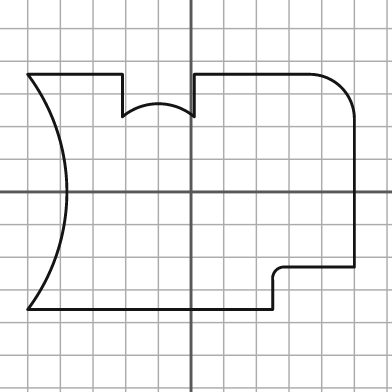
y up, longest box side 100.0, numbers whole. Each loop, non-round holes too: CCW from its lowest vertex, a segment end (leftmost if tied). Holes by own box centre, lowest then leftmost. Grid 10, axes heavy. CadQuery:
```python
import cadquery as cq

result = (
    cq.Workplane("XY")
    .moveTo(-50.0, -36.0)
    .lineTo(25.0, -36.0)
    .lineTo(25.0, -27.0)
    .threePointArc((26.0, -24.0), (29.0, -23.0))
    .lineTo(50.0, -23.0)
    .lineTo(50.0, 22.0)
    .threePointArc((46.0, 32.0), (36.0, 36.0))
    .lineTo(1.0, 36.0)
    .lineTo(1.0, 23.0)
    .threePointArc((-10.0, 27.0), (-21.0, 23.0))
    .lineTo(-21.0, 36.0)
    .lineTo(-50.0, 36.0)
    .threePointArc((-38.0, 0.0), (-50.0, -36.0))
    .close()
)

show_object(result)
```